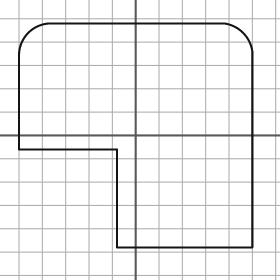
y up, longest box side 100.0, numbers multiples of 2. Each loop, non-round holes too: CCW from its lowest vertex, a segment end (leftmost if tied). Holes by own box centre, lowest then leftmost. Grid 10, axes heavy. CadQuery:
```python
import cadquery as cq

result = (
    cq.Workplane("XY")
    .moveTo(-8.0, -48.0)
    .lineTo(50.0, -48.0)
    .lineTo(50.0, 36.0)
    .threePointArc((46.0, 44.0), (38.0, 48.0))
    .lineTo(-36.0, 48.0)
    .threePointArc((-46.0, 44.0), (-50.0, 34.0))
    .lineTo(-50.0, -6.0)
    .lineTo(-8.0, -6.0)
    .close()
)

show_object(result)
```